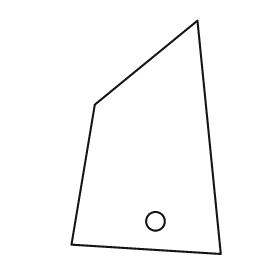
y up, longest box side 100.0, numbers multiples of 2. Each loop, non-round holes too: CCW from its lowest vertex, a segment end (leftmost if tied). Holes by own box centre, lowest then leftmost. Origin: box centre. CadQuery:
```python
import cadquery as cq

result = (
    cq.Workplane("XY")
    .moveTo(32.0, -50.0)
    .lineTo(22.0, 50.0)
    .lineTo(-22.0, 14.0)
    .lineTo(-32.0, -46.0)
    .close()
    .moveTo(4.0, -36.0)
    .circle(4.0)
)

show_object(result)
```